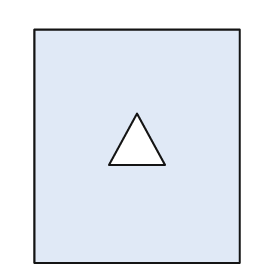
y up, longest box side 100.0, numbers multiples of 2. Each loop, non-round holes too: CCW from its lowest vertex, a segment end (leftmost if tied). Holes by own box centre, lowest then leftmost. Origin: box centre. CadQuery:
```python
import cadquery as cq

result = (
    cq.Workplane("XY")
    .moveTo(-44.0, -50.0)
    .lineTo(44.0, -50.0)
    .lineTo(44.0, 50.0)
    .lineTo(-44.0, 50.0)
    .close()
    .moveTo(-12.0, -8.0)
    .lineTo(12.0, -8.0)
    .lineTo(0.0, 14.0)
    .close()
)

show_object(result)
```